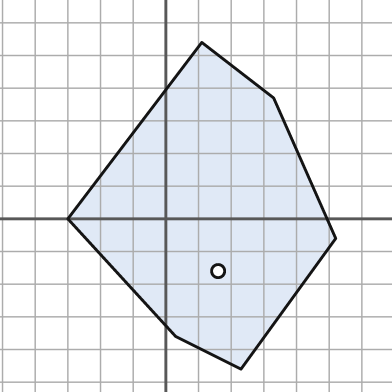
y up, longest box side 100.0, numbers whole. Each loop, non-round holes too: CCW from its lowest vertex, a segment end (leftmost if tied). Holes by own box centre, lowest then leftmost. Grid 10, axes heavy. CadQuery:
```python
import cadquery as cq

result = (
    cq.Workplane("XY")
    .moveTo(23.0, -46.0)
    .lineTo(52.0, -6.0)
    .lineTo(33.0, 37.0)
    .lineTo(11.0, 54.0)
    .lineTo(-30.0, 0.0)
    .lineTo(3.0, -36.0)
    .close()
    .moveTo(16.0, -16.0)
    .circle(2.0)
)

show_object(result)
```